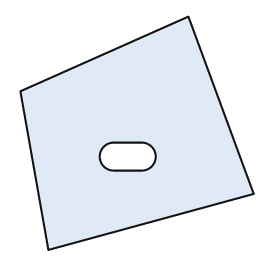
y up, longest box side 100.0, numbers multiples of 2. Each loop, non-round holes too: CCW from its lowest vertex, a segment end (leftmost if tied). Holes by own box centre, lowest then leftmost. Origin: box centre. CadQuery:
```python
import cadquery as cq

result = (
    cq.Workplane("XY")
    .moveTo(-38.0, -50.0)
    .lineTo(50.0, -26.0)
    .lineTo(22.0, 50.0)
    .lineTo(-50.0, 18.0)
    .close()
    .moveTo(-10.0, -16.0)
    .lineTo(2.0, -16.0)
    .threePointArc((8.0, -10.0), (2.0, -4.0))
    .lineTo(-10.0, -4.0)
    .threePointArc((-16.0, -10.0), (-10.0, -16.0))
    .close()
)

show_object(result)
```